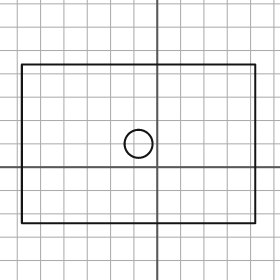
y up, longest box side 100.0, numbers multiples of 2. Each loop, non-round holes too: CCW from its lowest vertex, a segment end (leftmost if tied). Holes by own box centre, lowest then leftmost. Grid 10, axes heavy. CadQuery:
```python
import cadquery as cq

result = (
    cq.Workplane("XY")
    .moveTo(-58.0, -24.0)
    .lineTo(42.0, -24.0)
    .lineTo(42.0, 44.0)
    .lineTo(-58.0, 44.0)
    .close()
    .moveTo(-8.0, 10.0)
    .circle(6.0)
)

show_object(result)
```